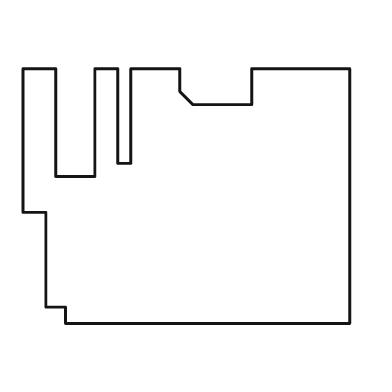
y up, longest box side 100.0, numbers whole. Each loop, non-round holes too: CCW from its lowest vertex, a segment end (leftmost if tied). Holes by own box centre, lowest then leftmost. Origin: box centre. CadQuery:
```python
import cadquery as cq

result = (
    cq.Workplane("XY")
    .moveTo(-37.0, -39.0)
    .lineTo(50.0, -39.0)
    .lineTo(50.0, 39.0)
    .lineTo(20.0, 39.0)
    .lineTo(20.0, 28.0)
    .lineTo(2.0, 28.0)
    .lineTo(-2.0, 32.0)
    .lineTo(-2.0, 39.0)
    .lineTo(-17.0, 39.0)
    .lineTo(-17.0, 10.0)
    .lineTo(-21.0, 10.0)
    .lineTo(-21.0, 39.0)
    .lineTo(-28.0, 39.0)
    .lineTo(-28.0, 6.0)
    .lineTo(-40.0, 6.0)
    .lineTo(-40.0, 39.0)
    .lineTo(-50.0, 39.0)
    .lineTo(-50.0, -5.0)
    .lineTo(-43.0, -5.0)
    .lineTo(-43.0, -34.0)
    .lineTo(-37.0, -34.0)
    .close()
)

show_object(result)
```